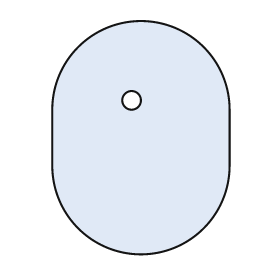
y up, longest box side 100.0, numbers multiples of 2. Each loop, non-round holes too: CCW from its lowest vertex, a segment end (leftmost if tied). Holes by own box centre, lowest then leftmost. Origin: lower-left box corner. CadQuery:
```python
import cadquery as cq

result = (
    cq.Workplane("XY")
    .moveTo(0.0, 38.0)
    .threePointArc((38.0, 0.0), (76.0, 38.0))
    .lineTo(76.0, 62.0)
    .threePointArc((38.0, 100.0), (0.0, 62.0))
    .close()
    .moveTo(34.0, 66.0)
    .circle(4.0)
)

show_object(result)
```